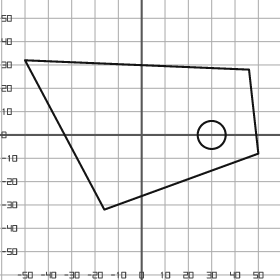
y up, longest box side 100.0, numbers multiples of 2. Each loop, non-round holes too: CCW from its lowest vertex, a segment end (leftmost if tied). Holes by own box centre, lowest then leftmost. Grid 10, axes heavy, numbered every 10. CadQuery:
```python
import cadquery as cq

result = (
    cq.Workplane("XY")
    .moveTo(-16.0, -32.0)
    .lineTo(50.0, -8.0)
    .lineTo(46.0, 28.0)
    .lineTo(-50.0, 32.0)
    .close()
    .moveTo(30.0, 0.0)
    .circle(6.0)
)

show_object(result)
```